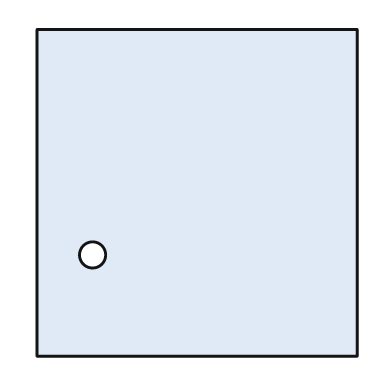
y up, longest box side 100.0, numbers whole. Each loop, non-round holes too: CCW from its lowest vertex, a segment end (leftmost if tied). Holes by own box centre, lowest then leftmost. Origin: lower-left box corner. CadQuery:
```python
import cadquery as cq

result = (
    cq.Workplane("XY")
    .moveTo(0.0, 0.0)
    .lineTo(98.0, 0.0)
    .lineTo(98.0, 100.0)
    .lineTo(0.0, 100.0)
    .close()
    .moveTo(17.0, 31.0)
    .circle(4.0)
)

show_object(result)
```